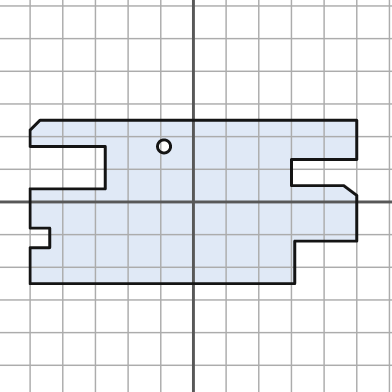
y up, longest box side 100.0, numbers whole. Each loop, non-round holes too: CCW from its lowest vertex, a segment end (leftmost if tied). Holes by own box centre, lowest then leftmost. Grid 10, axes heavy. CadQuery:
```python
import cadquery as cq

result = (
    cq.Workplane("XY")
    .moveTo(-50.0, -25.0)
    .lineTo(31.0, -25.0)
    .lineTo(31.0, -12.0)
    .lineTo(50.0, -12.0)
    .lineTo(50.0, 2.0)
    .lineTo(46.0, 5.0)
    .lineTo(30.0, 5.0)
    .lineTo(30.0, 13.0)
    .lineTo(50.0, 13.0)
    .lineTo(50.0, 25.0)
    .lineTo(-47.0, 25.0)
    .lineTo(-50.0, 22.0)
    .lineTo(-50.0, 17.0)
    .lineTo(-27.0, 17.0)
    .lineTo(-27.0, 4.0)
    .lineTo(-50.0, 4.0)
    .lineTo(-50.0, -8.0)
    .lineTo(-44.0, -8.0)
    .lineTo(-44.0, -14.0)
    .lineTo(-50.0, -14.0)
    .close()
    .moveTo(-9.0, 17.0)
    .circle(2.0)
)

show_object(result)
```